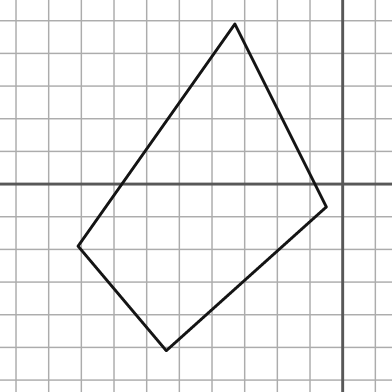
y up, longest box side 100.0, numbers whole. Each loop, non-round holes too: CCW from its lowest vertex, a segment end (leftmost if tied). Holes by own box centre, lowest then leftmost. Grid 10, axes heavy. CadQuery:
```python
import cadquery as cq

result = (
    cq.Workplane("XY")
    .moveTo(-54.0, -51.0)
    .lineTo(-5.0, -7.0)
    .lineTo(-33.0, 49.0)
    .lineTo(-81.0, -19.0)
    .close()
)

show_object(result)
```